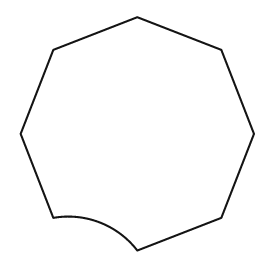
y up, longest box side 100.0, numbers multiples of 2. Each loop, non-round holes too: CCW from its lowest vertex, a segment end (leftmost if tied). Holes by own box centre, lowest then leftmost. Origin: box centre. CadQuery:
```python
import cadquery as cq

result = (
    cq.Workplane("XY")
    .moveTo(0.0, -50.0)
    .lineTo(36.0, -36.0)
    .lineTo(50.0, 0.0)
    .lineTo(36.0, 36.0)
    .lineTo(0.0, 50.0)
    .lineTo(-36.0, 36.0)
    .lineTo(-50.0, 0.0)
    .lineTo(-36.0, -36.0)
    .threePointArc((-16.0, -38.0), (0.0, -50.0))
    .close()
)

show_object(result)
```